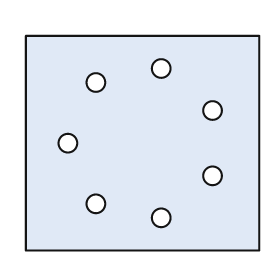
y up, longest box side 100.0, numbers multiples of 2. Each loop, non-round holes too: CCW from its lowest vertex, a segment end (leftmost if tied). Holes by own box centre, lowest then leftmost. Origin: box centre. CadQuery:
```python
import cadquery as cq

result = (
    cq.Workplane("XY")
    .moveTo(-50.0, -46.0)
    .lineTo(50.0, -46.0)
    .lineTo(50.0, 46.0)
    .lineTo(-50.0, 46.0)
    .close()
    .moveTo(8.0, -32.0)
    .circle(4.0)
    .moveTo(-20.0, -26.0)
    .circle(4.0)
    .moveTo(30.0, -14.0)
    .circle(4.0)
    .moveTo(-32.0, 0.0)
    .circle(4.0)
    .moveTo(30.0, 14.0)
    .circle(4.0)
    .moveTo(-20.0, 26.0)
    .circle(4.0)
    .moveTo(8.0, 32.0)
    .circle(4.0)
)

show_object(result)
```